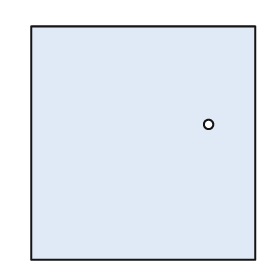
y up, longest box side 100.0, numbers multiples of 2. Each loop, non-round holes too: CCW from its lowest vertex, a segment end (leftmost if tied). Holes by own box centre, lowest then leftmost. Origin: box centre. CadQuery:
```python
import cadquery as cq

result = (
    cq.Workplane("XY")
    .moveTo(-48.0, -50.0)
    .lineTo(48.0, -50.0)
    .lineTo(48.0, 50.0)
    .lineTo(-48.0, 50.0)
    .close()
    .moveTo(28.0, 8.0)
    .circle(2.0)
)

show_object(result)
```